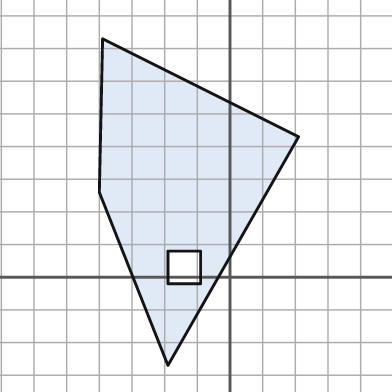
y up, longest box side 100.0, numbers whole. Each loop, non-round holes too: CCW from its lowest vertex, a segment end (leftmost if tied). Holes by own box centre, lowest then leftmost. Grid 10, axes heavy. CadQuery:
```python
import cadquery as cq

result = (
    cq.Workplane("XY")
    .moveTo(-19.0, -27.0)
    .lineTo(21.0, 43.0)
    .lineTo(-39.0, 73.0)
    .lineTo(-40.0, 26.0)
    .close()
    .moveTo(-19.0, -2.0)
    .lineTo(-9.0, -2.0)
    .lineTo(-9.0, 8.0)
    .lineTo(-19.0, 8.0)
    .close()
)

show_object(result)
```